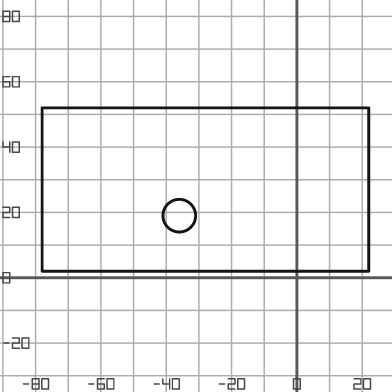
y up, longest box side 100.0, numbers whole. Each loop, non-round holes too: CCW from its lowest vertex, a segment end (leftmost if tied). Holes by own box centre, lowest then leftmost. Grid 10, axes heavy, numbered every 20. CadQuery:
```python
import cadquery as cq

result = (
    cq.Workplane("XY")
    .moveTo(-78.0, 2.0)
    .lineTo(22.0, 2.0)
    .lineTo(22.0, 52.0)
    .lineTo(-78.0, 52.0)
    .close()
    .moveTo(-36.0, 19.0)
    .circle(5.0)
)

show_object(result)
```